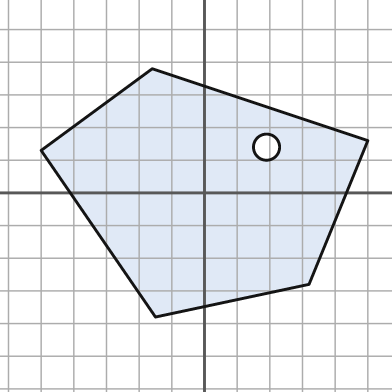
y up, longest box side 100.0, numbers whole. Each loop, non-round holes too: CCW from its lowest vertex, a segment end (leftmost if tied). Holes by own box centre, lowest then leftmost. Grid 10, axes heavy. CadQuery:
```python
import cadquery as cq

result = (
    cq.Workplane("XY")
    .moveTo(-15.0, -38.0)
    .lineTo(32.0, -28.0)
    .lineTo(50.0, 16.0)
    .lineTo(-16.0, 38.0)
    .lineTo(-50.0, 13.0)
    .close()
    .moveTo(19.0, 14.0)
    .circle(4.0)
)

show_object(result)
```